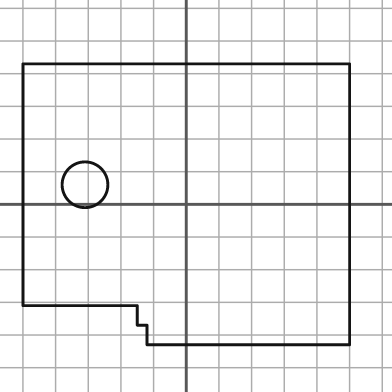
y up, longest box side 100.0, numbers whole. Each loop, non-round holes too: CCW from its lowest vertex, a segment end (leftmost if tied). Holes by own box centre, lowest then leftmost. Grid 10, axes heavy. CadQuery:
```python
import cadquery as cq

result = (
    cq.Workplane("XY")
    .moveTo(-12.0, -43.0)
    .lineTo(50.0, -43.0)
    .lineTo(50.0, 43.0)
    .lineTo(-50.0, 43.0)
    .lineTo(-50.0, -31.0)
    .lineTo(-15.0, -31.0)
    .lineTo(-15.0, -37.0)
    .lineTo(-12.0, -37.0)
    .close()
    .moveTo(-31.0, 6.0)
    .circle(7.0)
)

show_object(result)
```